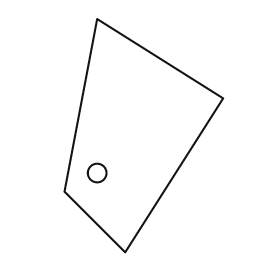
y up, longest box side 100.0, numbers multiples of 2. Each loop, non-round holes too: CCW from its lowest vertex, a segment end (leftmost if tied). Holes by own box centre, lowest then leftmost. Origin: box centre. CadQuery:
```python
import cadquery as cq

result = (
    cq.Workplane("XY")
    .moveTo(-8.0, -50.0)
    .lineTo(34.0, 16.0)
    .lineTo(-20.0, 50.0)
    .lineTo(-34.0, -24.0)
    .close()
    .moveTo(-20.0, -16.0)
    .circle(4.0)
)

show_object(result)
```